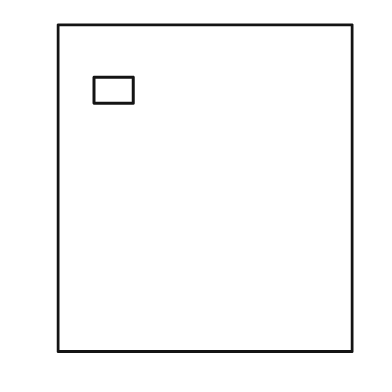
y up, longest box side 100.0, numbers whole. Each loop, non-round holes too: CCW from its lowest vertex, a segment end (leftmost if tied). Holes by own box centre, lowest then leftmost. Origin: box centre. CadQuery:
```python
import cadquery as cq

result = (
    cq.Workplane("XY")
    .moveTo(-45.0, -50.0)
    .lineTo(45.0, -50.0)
    .lineTo(45.0, 50.0)
    .lineTo(-45.0, 50.0)
    .close()
    .moveTo(-34.0, 26.0)
    .lineTo(-22.0, 26.0)
    .lineTo(-22.0, 34.0)
    .lineTo(-34.0, 34.0)
    .close()
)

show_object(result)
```